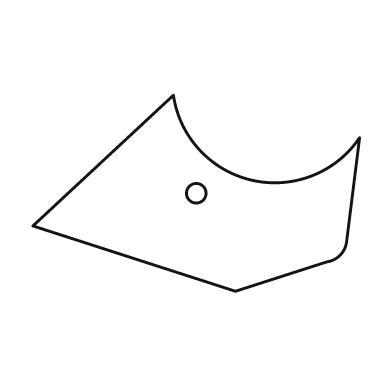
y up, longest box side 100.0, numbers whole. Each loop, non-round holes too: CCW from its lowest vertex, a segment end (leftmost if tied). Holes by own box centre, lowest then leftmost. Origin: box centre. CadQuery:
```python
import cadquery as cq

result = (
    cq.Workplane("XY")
    .moveTo(12.0, -30.0)
    .lineTo(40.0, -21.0)
    .threePointArc((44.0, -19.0), (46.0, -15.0))
    .lineTo(50.0, 17.0)
    .threePointArc((17.0, 4.0), (-7.0, 30.0))
    .lineTo(-50.0, -10.0)
    .close()
    .moveTo(0.0, 0.0)
    .circle(3.0)
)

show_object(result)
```